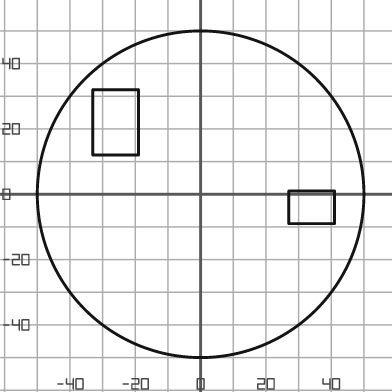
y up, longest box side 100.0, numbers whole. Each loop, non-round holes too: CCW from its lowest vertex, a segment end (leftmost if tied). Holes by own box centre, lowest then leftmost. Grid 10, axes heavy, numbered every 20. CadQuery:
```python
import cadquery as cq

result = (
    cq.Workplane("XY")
    .moveTo(0.0, 0.0)
    .circle(50.0)
    .moveTo(27.0, -9.0)
    .lineTo(41.0, -9.0)
    .lineTo(41.0, 1.0)
    .lineTo(27.0, 1.0)
    .close()
    .moveTo(-33.0, 12.0)
    .lineTo(-19.0, 12.0)
    .lineTo(-19.0, 32.0)
    .lineTo(-33.0, 32.0)
    .close()
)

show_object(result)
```